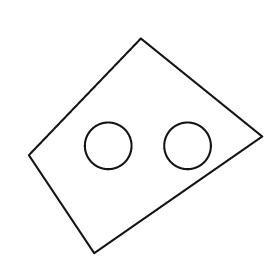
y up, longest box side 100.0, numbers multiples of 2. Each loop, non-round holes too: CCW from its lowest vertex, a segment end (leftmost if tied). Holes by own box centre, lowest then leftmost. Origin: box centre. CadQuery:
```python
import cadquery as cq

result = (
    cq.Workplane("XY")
    .moveTo(-22.0, -46.0)
    .lineTo(50.0, 4.0)
    .lineTo(-2.0, 46.0)
    .lineTo(-50.0, -4.0)
    .close()
    .moveTo(-16.0, 0.0)
    .circle(10.0)
    .moveTo(18.0, 0.0)
    .circle(10.0)
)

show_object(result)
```